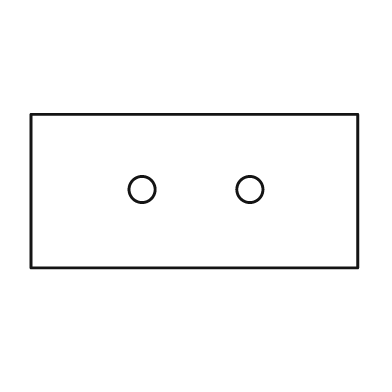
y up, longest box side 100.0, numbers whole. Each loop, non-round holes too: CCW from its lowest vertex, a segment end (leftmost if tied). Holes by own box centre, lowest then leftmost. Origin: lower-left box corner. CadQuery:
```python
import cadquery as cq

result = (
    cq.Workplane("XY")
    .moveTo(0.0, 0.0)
    .lineTo(100.0, 0.0)
    .lineTo(100.0, 47.0)
    .lineTo(0.0, 47.0)
    .close()
    .moveTo(34.0, 24.0)
    .circle(4.0)
    .moveTo(67.0, 24.0)
    .circle(4.0)
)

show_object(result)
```